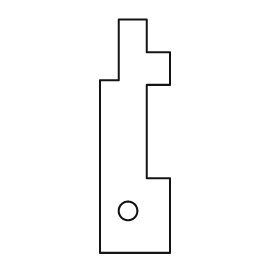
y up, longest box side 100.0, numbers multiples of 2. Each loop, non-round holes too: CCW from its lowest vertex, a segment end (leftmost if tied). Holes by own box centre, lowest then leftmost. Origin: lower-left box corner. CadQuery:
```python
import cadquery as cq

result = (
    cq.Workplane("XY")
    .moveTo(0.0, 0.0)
    .lineTo(30.0, 0.0)
    .lineTo(30.0, 32.0)
    .lineTo(20.0, 32.0)
    .lineTo(20.0, 72.0)
    .lineTo(30.0, 72.0)
    .lineTo(30.0, 86.0)
    .lineTo(20.0, 86.0)
    .lineTo(20.0, 100.0)
    .lineTo(8.0, 100.0)
    .lineTo(8.0, 74.0)
    .lineTo(0.0, 74.0)
    .close()
    .moveTo(12.0, 18.0)
    .circle(4.0)
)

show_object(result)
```